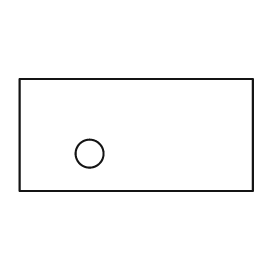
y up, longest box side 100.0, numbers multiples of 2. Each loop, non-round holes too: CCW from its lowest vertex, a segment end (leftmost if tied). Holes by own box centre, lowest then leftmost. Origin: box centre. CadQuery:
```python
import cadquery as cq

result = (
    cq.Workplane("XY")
    .moveTo(-50.0, -24.0)
    .lineTo(50.0, -24.0)
    .lineTo(50.0, 24.0)
    .lineTo(-50.0, 24.0)
    .close()
    .moveTo(-20.0, -8.0)
    .circle(6.0)
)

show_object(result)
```